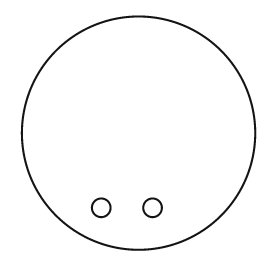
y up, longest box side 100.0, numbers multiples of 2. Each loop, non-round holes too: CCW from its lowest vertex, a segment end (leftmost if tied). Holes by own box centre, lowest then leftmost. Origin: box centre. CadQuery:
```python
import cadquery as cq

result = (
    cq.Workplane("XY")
    .moveTo(0.0, 0.0)
    .circle(50.0)
    .moveTo(-16.0, -32.0)
    .circle(4.0)
    .moveTo(6.0, -32.0)
    .circle(4.0)
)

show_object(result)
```